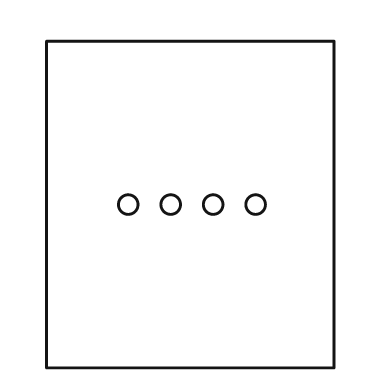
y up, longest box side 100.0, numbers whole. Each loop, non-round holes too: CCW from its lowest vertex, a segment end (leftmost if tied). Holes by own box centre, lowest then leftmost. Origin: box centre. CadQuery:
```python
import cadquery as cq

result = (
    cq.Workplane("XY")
    .moveTo(-44.0, -50.0)
    .lineTo(44.0, -50.0)
    .lineTo(44.0, 50.0)
    .lineTo(-44.0, 50.0)
    .close()
    .moveTo(-19.0, 0.0)
    .circle(3.0)
    .moveTo(-6.0, 0.0)
    .circle(3.0)
    .moveTo(7.0, 0.0)
    .circle(3.0)
    .moveTo(20.0, 0.0)
    .circle(3.0)
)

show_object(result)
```